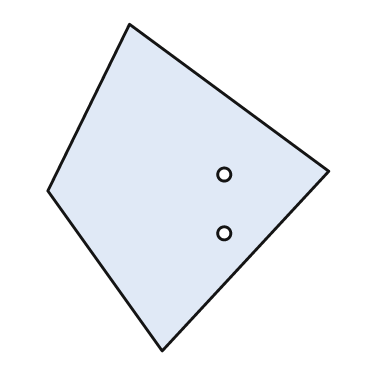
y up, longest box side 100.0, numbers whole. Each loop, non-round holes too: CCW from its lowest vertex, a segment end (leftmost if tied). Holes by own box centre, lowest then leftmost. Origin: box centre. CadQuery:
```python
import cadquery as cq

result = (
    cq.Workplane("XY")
    .moveTo(-8.0, -50.0)
    .lineTo(43.0, 5.0)
    .lineTo(-18.0, 50.0)
    .lineTo(-43.0, -1.0)
    .close()
    .moveTo(11.0, -14.0)
    .circle(2.0)
    .moveTo(11.0, 4.0)
    .circle(2.0)
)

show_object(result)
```